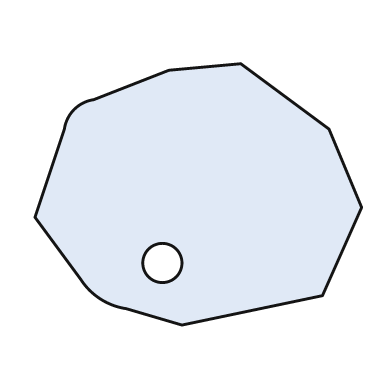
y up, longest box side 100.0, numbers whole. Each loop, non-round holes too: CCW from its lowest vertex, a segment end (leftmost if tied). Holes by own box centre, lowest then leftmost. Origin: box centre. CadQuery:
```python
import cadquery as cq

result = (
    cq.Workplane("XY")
    .moveTo(-5.0, -40.0)
    .lineTo(38.0, -31.0)
    .lineTo(50.0, -4.0)
    .lineTo(40.0, 20.0)
    .lineTo(13.0, 40.0)
    .lineTo(-9.0, 38.0)
    .lineTo(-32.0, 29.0)
    .threePointArc((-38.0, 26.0), (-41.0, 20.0))
    .lineTo(-50.0, -7.0)
    .lineTo(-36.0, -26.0)
    .threePointArc((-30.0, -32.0), (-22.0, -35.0))
    .close()
    .moveTo(-11.0, -21.0)
    .circle(6.0)
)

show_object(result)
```